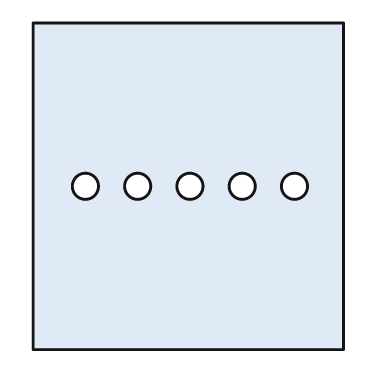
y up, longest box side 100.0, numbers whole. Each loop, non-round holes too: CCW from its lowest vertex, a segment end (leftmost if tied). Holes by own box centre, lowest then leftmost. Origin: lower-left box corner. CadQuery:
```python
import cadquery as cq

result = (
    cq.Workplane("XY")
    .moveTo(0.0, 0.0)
    .lineTo(95.0, 0.0)
    .lineTo(95.0, 100.0)
    .lineTo(0.0, 100.0)
    .close()
    .moveTo(16.0, 50.0)
    .circle(4.0)
    .moveTo(32.0, 50.0)
    .circle(4.0)
    .moveTo(48.0, 50.0)
    .circle(4.0)
    .moveTo(64.0, 50.0)
    .circle(4.0)
    .moveTo(80.0, 50.0)
    .circle(4.0)
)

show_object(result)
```